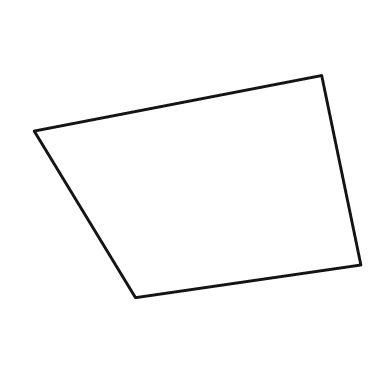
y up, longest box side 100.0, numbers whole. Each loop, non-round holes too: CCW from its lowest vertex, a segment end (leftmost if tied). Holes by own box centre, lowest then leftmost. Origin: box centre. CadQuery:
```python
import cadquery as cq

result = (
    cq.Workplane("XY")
    .moveTo(-19.0, -34.0)
    .lineTo(50.0, -24.0)
    .lineTo(38.0, 34.0)
    .lineTo(-50.0, 17.0)
    .close()
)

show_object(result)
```